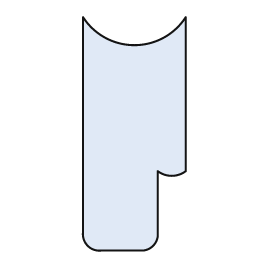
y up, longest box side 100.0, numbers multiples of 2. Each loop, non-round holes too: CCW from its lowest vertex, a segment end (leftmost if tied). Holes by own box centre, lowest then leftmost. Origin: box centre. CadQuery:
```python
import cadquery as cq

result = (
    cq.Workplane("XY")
    .moveTo(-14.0, -50.0)
    .lineTo(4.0, -50.0)
    .threePointArc((8.0, -48.0), (10.0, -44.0))
    .lineTo(10.0, -16.0)
    .threePointArc((16.0, -18.0), (22.0, -16.0))
    .lineTo(22.0, 50.0)
    .threePointArc((0.0, 38.0), (-22.0, 50.0))
    .lineTo(-22.0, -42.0)
    .threePointArc((-20.0, -48.0), (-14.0, -50.0))
    .close()
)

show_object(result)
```